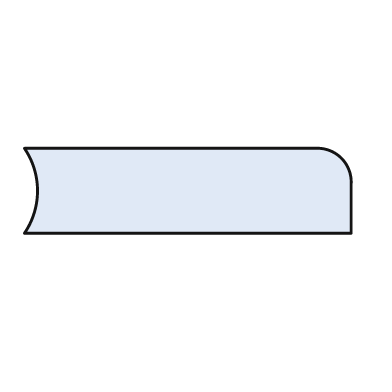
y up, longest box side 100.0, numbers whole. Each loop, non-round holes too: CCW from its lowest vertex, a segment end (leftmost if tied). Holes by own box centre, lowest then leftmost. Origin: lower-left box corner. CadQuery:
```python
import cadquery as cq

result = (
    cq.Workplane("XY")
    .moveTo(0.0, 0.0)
    .lineTo(100.0, 0.0)
    .lineTo(100.0, 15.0)
    .threePointArc((97.0, 23.0), (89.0, 26.0))
    .lineTo(0.0, 26.0)
    .threePointArc((4.0, 13.0), (0.0, 0.0))
    .close()
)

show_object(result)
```